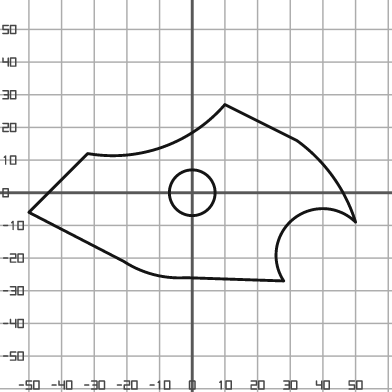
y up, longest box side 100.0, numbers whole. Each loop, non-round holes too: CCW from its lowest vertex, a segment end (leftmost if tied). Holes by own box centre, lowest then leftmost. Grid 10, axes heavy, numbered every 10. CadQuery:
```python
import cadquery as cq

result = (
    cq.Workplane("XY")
    .moveTo(28.0, -27.0)
    .threePointArc((31.0, -8.0), (50.0, -9.0))
    .threePointArc((43.0, 5.0), (32.0, 16.0))
    .lineTo(10.0, 27.0)
    .threePointArc((-9.0, 14.0), (-32.0, 12.0))
    .lineTo(-50.0, -6.0)
    .lineTo(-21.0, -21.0)
    .threePointArc((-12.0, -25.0), (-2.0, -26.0))
    .close()
    .moveTo(0.0, 0.0)
    .circle(7.0)
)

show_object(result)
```